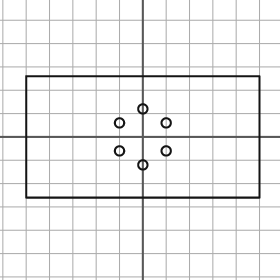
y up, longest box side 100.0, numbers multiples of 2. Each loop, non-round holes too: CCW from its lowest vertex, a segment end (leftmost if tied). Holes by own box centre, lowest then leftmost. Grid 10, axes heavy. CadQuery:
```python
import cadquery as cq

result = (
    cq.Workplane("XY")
    .moveTo(-50.0, -26.0)
    .lineTo(50.0, -26.0)
    .lineTo(50.0, 26.0)
    .lineTo(-50.0, 26.0)
    .close()
    .moveTo(0.0, -12.0)
    .circle(2.0)
    .moveTo(-10.0, -6.0)
    .circle(2.0)
    .moveTo(10.0, -6.0)
    .circle(2.0)
    .moveTo(-10.0, 6.0)
    .circle(2.0)
    .moveTo(10.0, 6.0)
    .circle(2.0)
    .moveTo(0.0, 12.0)
    .circle(2.0)
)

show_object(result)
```